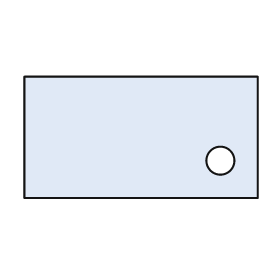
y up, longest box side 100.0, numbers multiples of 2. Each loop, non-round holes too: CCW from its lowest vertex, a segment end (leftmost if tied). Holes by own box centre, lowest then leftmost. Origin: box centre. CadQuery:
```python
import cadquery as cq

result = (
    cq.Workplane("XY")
    .moveTo(-50.0, -26.0)
    .lineTo(50.0, -26.0)
    .lineTo(50.0, 26.0)
    .lineTo(-50.0, 26.0)
    .close()
    .moveTo(34.0, -10.0)
    .circle(6.0)
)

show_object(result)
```